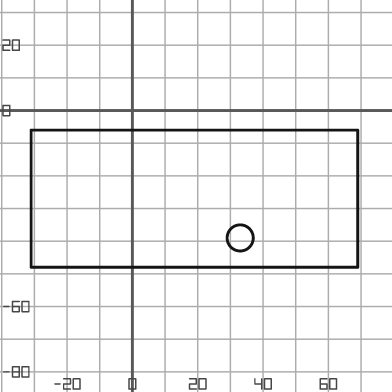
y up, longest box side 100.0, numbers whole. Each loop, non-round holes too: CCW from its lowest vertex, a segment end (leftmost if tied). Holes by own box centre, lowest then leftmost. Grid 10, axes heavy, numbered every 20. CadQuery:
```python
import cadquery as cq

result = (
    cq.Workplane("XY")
    .moveTo(-31.0, -48.0)
    .lineTo(69.0, -48.0)
    .lineTo(69.0, -6.0)
    .lineTo(-31.0, -6.0)
    .close()
    .moveTo(33.0, -39.0)
    .circle(4.0)
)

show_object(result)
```